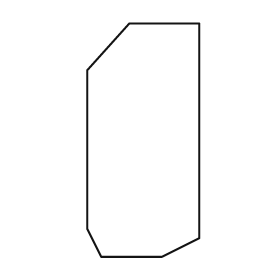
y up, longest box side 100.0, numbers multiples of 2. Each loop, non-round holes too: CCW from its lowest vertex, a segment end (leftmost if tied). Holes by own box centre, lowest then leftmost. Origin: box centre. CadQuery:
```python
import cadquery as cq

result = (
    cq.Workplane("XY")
    .moveTo(-18.0, -50.0)
    .lineTo(8.0, -50.0)
    .lineTo(24.0, -42.0)
    .lineTo(24.0, 50.0)
    .lineTo(-6.0, 50.0)
    .lineTo(-24.0, 30.0)
    .lineTo(-24.0, -38.0)
    .close()
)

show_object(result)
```